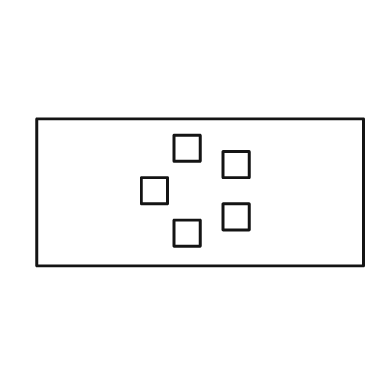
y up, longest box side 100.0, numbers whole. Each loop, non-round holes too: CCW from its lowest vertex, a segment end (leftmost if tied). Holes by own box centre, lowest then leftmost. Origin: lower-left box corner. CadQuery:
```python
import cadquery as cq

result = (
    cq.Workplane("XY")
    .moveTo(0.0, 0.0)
    .lineTo(100.0, 0.0)
    .lineTo(100.0, 45.0)
    .lineTo(0.0, 45.0)
    .close()
    .moveTo(42.0, 6.0)
    .lineTo(50.0, 6.0)
    .lineTo(50.0, 14.0)
    .lineTo(42.0, 14.0)
    .close()
    .moveTo(57.0, 11.0)
    .lineTo(65.0, 11.0)
    .lineTo(65.0, 19.0)
    .lineTo(57.0, 19.0)
    .close()
    .moveTo(32.0, 19.0)
    .lineTo(40.0, 19.0)
    .lineTo(40.0, 27.0)
    .lineTo(32.0, 27.0)
    .close()
    .moveTo(57.0, 27.0)
    .lineTo(65.0, 27.0)
    .lineTo(65.0, 35.0)
    .lineTo(57.0, 35.0)
    .close()
    .moveTo(42.0, 32.0)
    .lineTo(50.0, 32.0)
    .lineTo(50.0, 40.0)
    .lineTo(42.0, 40.0)
    .close()
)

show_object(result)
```